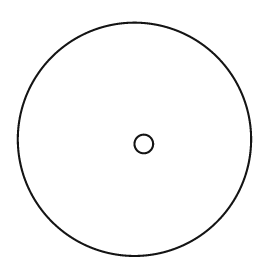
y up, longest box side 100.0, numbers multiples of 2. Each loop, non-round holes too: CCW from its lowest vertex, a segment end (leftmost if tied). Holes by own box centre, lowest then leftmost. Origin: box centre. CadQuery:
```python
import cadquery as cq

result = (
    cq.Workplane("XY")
    .moveTo(0.0, 0.0)
    .circle(50.0)
    .moveTo(4.0, -2.0)
    .circle(4.0)
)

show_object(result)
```